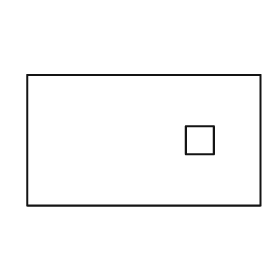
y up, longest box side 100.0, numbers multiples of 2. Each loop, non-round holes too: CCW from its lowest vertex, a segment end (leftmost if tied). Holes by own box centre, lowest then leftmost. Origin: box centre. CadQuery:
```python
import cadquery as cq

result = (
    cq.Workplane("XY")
    .moveTo(-50.0, -28.0)
    .lineTo(50.0, -28.0)
    .lineTo(50.0, 28.0)
    .lineTo(-50.0, 28.0)
    .close()
    .moveTo(18.0, -6.0)
    .lineTo(30.0, -6.0)
    .lineTo(30.0, 6.0)
    .lineTo(18.0, 6.0)
    .close()
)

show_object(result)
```